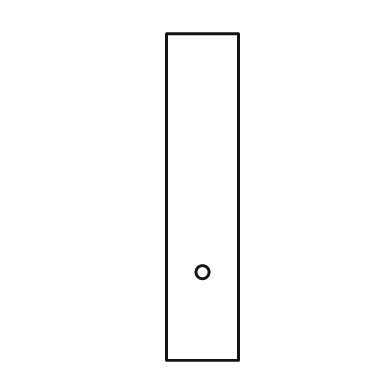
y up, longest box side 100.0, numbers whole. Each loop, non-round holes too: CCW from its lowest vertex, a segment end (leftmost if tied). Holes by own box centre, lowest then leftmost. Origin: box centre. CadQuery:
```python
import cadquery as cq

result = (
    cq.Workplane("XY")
    .moveTo(-11.0, -50.0)
    .lineTo(11.0, -50.0)
    .lineTo(11.0, 50.0)
    .lineTo(-11.0, 50.0)
    .close()
    .moveTo(0.0, -23.0)
    .circle(2.0)
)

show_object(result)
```